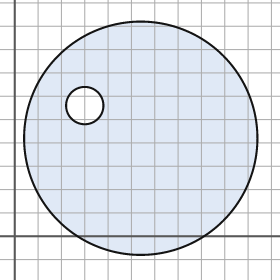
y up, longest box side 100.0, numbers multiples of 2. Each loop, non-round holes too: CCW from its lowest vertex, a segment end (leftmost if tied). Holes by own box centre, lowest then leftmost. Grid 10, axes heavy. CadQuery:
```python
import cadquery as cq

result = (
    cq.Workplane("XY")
    .moveTo(54.0, 42.0)
    .circle(50.0)
    .moveTo(30.0, 56.0)
    .circle(8.0)
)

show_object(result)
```